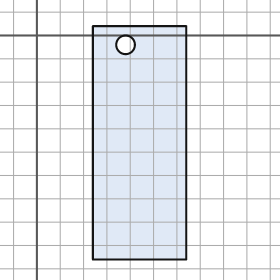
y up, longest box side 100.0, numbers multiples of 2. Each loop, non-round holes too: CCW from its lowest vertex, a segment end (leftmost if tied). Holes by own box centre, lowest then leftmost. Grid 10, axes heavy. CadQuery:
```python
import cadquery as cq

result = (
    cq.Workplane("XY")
    .moveTo(24.0, -96.0)
    .lineTo(64.0, -96.0)
    .lineTo(64.0, 4.0)
    .lineTo(24.0, 4.0)
    .close()
    .moveTo(38.0, -4.0)
    .circle(4.0)
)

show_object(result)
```